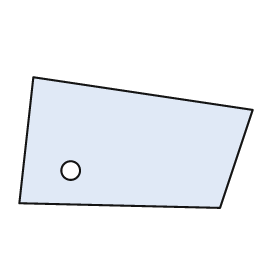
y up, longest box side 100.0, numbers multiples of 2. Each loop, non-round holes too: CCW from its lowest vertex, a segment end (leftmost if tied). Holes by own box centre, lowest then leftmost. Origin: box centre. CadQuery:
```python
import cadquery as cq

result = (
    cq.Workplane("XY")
    .moveTo(36.0, -28.0)
    .lineTo(50.0, 14.0)
    .lineTo(-44.0, 28.0)
    .lineTo(-50.0, -26.0)
    .close()
    .moveTo(-28.0, -12.0)
    .circle(4.0)
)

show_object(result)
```